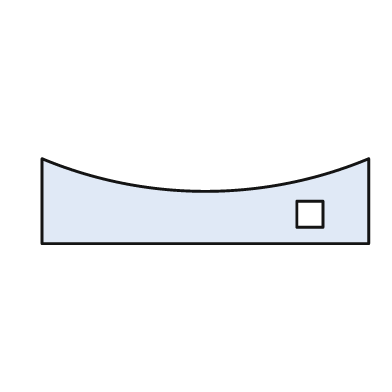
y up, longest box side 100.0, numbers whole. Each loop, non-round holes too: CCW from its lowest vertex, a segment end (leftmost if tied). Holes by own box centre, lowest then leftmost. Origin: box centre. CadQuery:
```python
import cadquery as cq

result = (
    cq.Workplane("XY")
    .moveTo(-50.0, -13.0)
    .lineTo(50.0, -13.0)
    .lineTo(50.0, 13.0)
    .threePointArc((0.0, 3.0), (-50.0, 13.0))
    .close()
    .moveTo(28.0, -8.0)
    .lineTo(36.0, -8.0)
    .lineTo(36.0, 0.0)
    .lineTo(28.0, 0.0)
    .close()
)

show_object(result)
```